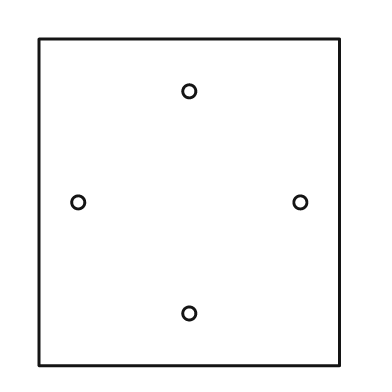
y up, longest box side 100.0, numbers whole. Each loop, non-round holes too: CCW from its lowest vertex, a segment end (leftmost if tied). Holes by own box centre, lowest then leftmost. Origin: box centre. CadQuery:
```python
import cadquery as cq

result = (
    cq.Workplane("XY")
    .moveTo(-46.0, -50.0)
    .lineTo(46.0, -50.0)
    .lineTo(46.0, 50.0)
    .lineTo(-46.0, 50.0)
    .close()
    .moveTo(0.0, -34.0)
    .circle(2.0)
    .moveTo(-34.0, 0.0)
    .circle(2.0)
    .moveTo(34.0, 0.0)
    .circle(2.0)
    .moveTo(0.0, 34.0)
    .circle(2.0)
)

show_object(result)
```